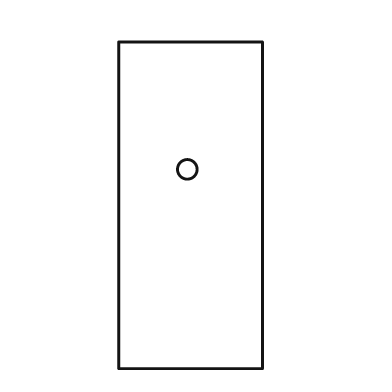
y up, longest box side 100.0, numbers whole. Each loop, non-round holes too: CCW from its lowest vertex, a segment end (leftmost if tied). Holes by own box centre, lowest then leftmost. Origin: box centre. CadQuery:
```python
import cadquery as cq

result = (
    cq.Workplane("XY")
    .moveTo(-22.0, -50.0)
    .lineTo(22.0, -50.0)
    .lineTo(22.0, 50.0)
    .lineTo(-22.0, 50.0)
    .close()
    .moveTo(-1.0, 11.0)
    .circle(3.0)
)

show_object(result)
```